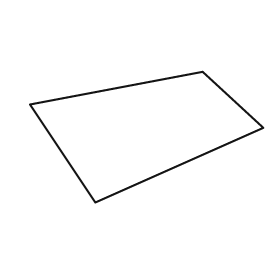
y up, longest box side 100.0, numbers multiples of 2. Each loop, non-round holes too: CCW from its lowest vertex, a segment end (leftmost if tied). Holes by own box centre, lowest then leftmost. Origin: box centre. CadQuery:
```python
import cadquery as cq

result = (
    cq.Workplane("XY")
    .moveTo(-22.0, -28.0)
    .lineTo(50.0, 4.0)
    .lineTo(24.0, 28.0)
    .lineTo(-50.0, 14.0)
    .close()
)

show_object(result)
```